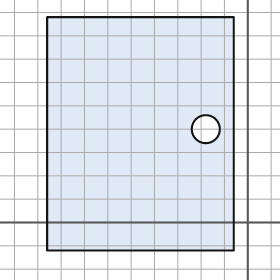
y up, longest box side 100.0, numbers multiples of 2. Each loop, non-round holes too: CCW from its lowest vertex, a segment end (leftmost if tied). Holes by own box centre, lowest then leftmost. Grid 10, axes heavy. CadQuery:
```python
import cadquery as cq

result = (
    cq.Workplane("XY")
    .moveTo(-86.0, -12.0)
    .lineTo(-6.0, -12.0)
    .lineTo(-6.0, 88.0)
    .lineTo(-86.0, 88.0)
    .close()
    .moveTo(-18.0, 40.0)
    .circle(6.0)
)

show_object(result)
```